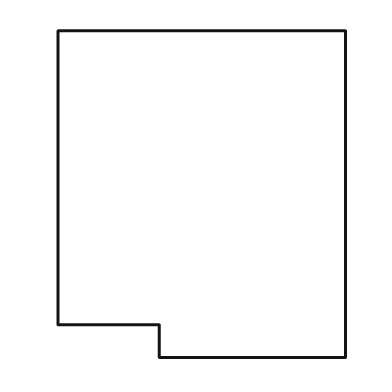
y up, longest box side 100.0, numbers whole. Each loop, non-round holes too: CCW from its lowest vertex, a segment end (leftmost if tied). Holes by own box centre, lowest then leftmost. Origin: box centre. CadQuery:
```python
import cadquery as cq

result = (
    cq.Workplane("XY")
    .moveTo(-13.0, -50.0)
    .lineTo(44.0, -50.0)
    .lineTo(44.0, 50.0)
    .lineTo(-44.0, 50.0)
    .lineTo(-44.0, -40.0)
    .lineTo(-13.0, -40.0)
    .close()
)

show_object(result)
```